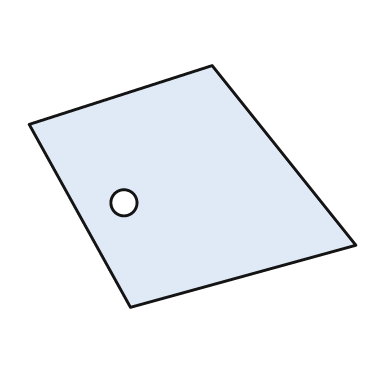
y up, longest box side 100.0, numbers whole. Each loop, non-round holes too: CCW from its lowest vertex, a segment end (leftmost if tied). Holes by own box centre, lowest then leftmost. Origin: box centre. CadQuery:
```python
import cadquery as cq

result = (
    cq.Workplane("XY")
    .moveTo(-19.0, -37.0)
    .lineTo(50.0, -18.0)
    .lineTo(6.0, 37.0)
    .lineTo(-50.0, 19.0)
    .close()
    .moveTo(-21.0, -5.0)
    .circle(4.0)
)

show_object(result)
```